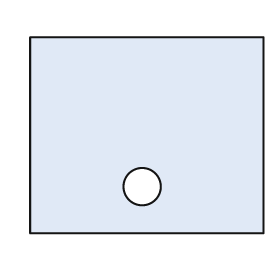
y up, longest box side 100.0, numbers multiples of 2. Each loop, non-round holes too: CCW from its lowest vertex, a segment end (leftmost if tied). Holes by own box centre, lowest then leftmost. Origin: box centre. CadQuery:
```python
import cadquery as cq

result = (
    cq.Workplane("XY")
    .moveTo(-50.0, -42.0)
    .lineTo(50.0, -42.0)
    .lineTo(50.0, 42.0)
    .lineTo(-50.0, 42.0)
    .close()
    .moveTo(-2.0, -22.0)
    .circle(8.0)
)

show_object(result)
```